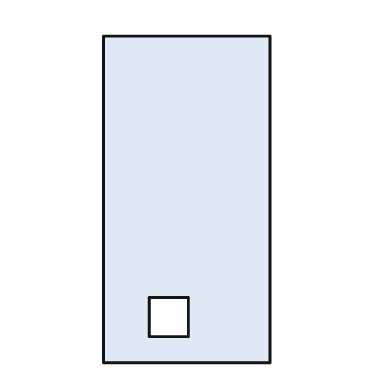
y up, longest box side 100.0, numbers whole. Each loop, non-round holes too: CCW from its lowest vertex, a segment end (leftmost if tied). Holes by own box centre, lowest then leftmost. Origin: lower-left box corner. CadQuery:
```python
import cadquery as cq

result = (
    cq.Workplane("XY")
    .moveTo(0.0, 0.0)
    .lineTo(51.0, 0.0)
    .lineTo(51.0, 100.0)
    .lineTo(0.0, 100.0)
    .close()
    .moveTo(14.0, 8.0)
    .lineTo(26.0, 8.0)
    .lineTo(26.0, 20.0)
    .lineTo(14.0, 20.0)
    .close()
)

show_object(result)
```